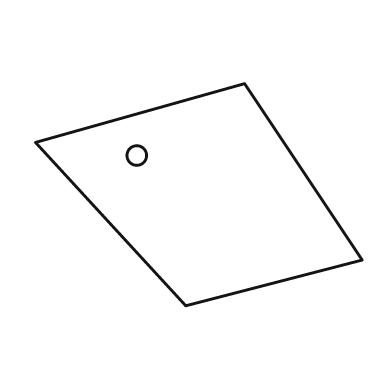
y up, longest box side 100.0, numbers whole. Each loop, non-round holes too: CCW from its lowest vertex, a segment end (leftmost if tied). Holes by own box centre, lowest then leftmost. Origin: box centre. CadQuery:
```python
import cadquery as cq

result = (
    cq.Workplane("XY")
    .moveTo(-4.0, -34.0)
    .lineTo(50.0, -20.0)
    .lineTo(14.0, 34.0)
    .lineTo(-50.0, 16.0)
    .close()
    .moveTo(-19.0, 12.0)
    .circle(3.0)
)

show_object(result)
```